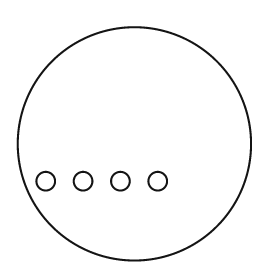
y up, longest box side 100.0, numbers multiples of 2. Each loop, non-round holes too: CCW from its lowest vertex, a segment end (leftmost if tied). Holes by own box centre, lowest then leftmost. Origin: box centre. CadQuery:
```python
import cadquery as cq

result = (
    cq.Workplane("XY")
    .moveTo(0.0, 0.0)
    .circle(50.0)
    .moveTo(-38.0, -16.0)
    .circle(4.0)
    .moveTo(-22.0, -16.0)
    .circle(4.0)
    .moveTo(-6.0, -16.0)
    .circle(4.0)
    .moveTo(10.0, -16.0)
    .circle(4.0)
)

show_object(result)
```